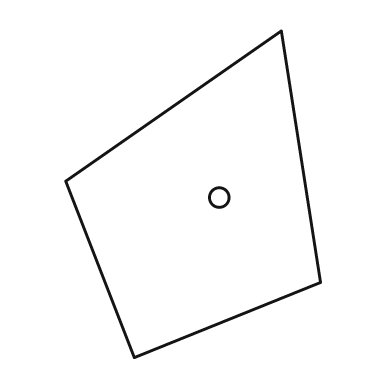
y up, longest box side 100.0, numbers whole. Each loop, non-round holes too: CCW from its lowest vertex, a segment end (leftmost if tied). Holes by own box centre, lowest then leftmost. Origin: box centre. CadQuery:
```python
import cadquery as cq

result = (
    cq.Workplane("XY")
    .moveTo(-18.0, -50.0)
    .lineTo(39.0, -27.0)
    .lineTo(27.0, 50.0)
    .lineTo(-39.0, 4.0)
    .close()
    .moveTo(8.0, -1.0)
    .circle(3.0)
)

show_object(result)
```